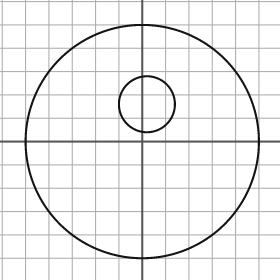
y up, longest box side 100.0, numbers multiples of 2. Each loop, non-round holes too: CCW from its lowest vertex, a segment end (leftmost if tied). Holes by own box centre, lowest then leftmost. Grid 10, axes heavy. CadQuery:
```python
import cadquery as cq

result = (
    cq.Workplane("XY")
    .moveTo(0.0, 0.0)
    .circle(50.0)
    .moveTo(2.0, 16.0)
    .circle(12.0)
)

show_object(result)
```